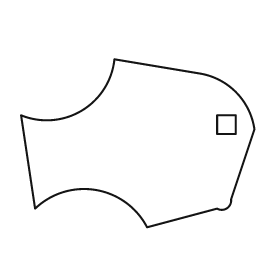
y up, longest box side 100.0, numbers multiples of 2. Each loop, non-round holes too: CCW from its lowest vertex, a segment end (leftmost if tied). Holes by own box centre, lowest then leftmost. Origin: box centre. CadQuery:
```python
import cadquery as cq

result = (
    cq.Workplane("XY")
    .moveTo(4.0, -36.0)
    .lineTo(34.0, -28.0)
    .threePointArc((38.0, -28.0), (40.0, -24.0))
    .lineTo(50.0, 6.0)
    .threePointArc((42.0, 22.0), (26.0, 30.0))
    .lineTo(-10.0, 36.0)
    .threePointArc((-24.0, 14.0), (-50.0, 12.0))
    .lineTo(-44.0, -28.0)
    .threePointArc((-18.0, -20.0), (4.0, -36.0))
    .close()
    .moveTo(34.0, 4.0)
    .lineTo(42.0, 4.0)
    .lineTo(42.0, 12.0)
    .lineTo(34.0, 12.0)
    .close()
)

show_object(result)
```